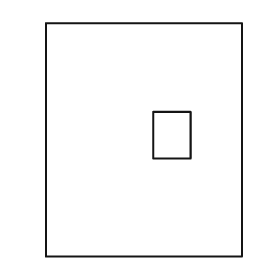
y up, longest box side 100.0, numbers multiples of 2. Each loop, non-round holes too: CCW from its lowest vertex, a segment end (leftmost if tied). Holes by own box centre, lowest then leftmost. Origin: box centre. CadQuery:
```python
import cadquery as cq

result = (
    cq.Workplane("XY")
    .moveTo(-42.0, -50.0)
    .lineTo(42.0, -50.0)
    .lineTo(42.0, 50.0)
    .lineTo(-42.0, 50.0)
    .close()
    .moveTo(4.0, -8.0)
    .lineTo(20.0, -8.0)
    .lineTo(20.0, 12.0)
    .lineTo(4.0, 12.0)
    .close()
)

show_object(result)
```